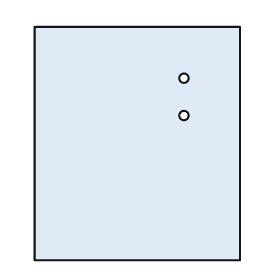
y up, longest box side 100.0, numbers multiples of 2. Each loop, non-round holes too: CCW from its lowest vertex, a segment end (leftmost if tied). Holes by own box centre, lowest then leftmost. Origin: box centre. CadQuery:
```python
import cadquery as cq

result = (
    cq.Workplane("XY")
    .moveTo(-44.0, -50.0)
    .lineTo(44.0, -50.0)
    .lineTo(44.0, 50.0)
    .lineTo(-44.0, 50.0)
    .close()
    .moveTo(20.0, 12.0)
    .circle(2.0)
    .moveTo(20.0, 28.0)
    .circle(2.0)
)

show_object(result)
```